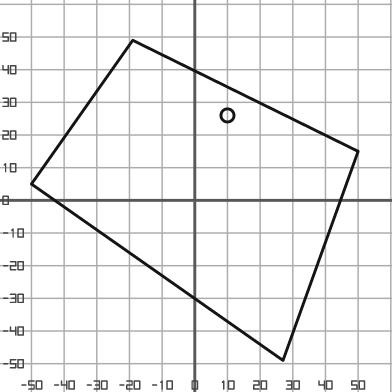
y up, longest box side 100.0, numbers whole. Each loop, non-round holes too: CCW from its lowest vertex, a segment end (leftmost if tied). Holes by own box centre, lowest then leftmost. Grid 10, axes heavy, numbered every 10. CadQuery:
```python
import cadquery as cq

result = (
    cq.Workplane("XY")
    .moveTo(27.0, -49.0)
    .lineTo(50.0, 15.0)
    .lineTo(-19.0, 49.0)
    .lineTo(-50.0, 5.0)
    .close()
    .moveTo(10.0, 26.0)
    .circle(2.0)
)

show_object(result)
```